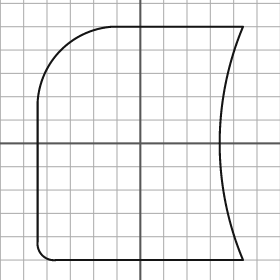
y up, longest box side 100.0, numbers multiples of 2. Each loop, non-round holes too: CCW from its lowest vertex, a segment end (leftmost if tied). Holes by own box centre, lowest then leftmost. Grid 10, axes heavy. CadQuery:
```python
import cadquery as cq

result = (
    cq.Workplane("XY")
    .moveTo(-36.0, -50.0)
    .lineTo(44.0, -50.0)
    .threePointArc((34.0, 0.0), (44.0, 50.0))
    .lineTo(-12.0, 50.0)
    .threePointArc((-34.0, 40.0), (-44.0, 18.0))
    .lineTo(-44.0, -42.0)
    .threePointArc((-42.0, -48.0), (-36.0, -50.0))
    .close()
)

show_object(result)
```